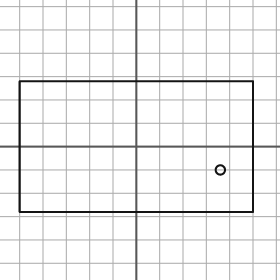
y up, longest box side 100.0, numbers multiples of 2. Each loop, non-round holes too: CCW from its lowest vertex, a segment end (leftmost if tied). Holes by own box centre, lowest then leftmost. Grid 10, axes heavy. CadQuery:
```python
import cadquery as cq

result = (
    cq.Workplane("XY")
    .moveTo(-50.0, -28.0)
    .lineTo(50.0, -28.0)
    .lineTo(50.0, 28.0)
    .lineTo(-50.0, 28.0)
    .close()
    .moveTo(36.0, -10.0)
    .circle(2.0)
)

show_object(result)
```